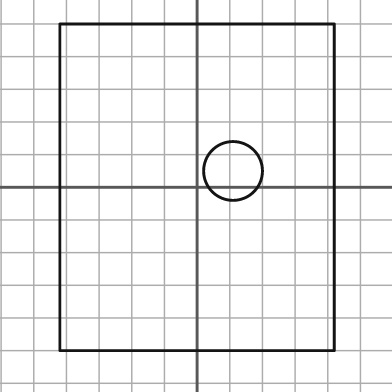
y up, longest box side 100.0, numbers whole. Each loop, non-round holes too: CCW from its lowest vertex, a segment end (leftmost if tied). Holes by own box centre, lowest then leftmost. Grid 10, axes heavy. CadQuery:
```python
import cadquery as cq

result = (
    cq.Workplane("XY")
    .moveTo(-42.0, -50.0)
    .lineTo(42.0, -50.0)
    .lineTo(42.0, 50.0)
    .lineTo(-42.0, 50.0)
    .close()
    .moveTo(11.0, 5.0)
    .circle(9.0)
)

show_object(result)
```